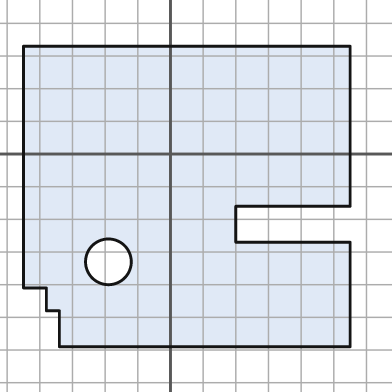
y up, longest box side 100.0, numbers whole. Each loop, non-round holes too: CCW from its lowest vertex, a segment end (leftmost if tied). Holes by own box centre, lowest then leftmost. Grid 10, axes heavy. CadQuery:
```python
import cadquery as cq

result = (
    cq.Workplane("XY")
    .moveTo(-34.0, -59.0)
    .lineTo(55.0, -59.0)
    .lineTo(55.0, -27.0)
    .lineTo(20.0, -27.0)
    .lineTo(20.0, -16.0)
    .lineTo(55.0, -16.0)
    .lineTo(55.0, 33.0)
    .lineTo(-45.0, 33.0)
    .lineTo(-45.0, -41.0)
    .lineTo(-38.0, -41.0)
    .lineTo(-38.0, -48.0)
    .lineTo(-34.0, -48.0)
    .close()
    .moveTo(-19.0, -33.0)
    .circle(7.0)
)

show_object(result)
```